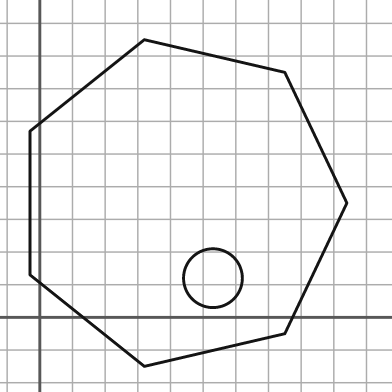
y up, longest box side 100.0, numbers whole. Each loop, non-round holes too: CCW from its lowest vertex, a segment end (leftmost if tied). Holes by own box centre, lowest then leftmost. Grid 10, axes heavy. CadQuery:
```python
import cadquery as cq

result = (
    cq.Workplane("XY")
    .moveTo(32.0, -15.0)
    .lineTo(75.0, -5.0)
    .lineTo(94.0, 35.0)
    .lineTo(75.0, 75.0)
    .lineTo(32.0, 85.0)
    .lineTo(-3.0, 57.0)
    .lineTo(-3.0, 13.0)
    .close()
    .moveTo(53.0, 12.0)
    .circle(9.0)
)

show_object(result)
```